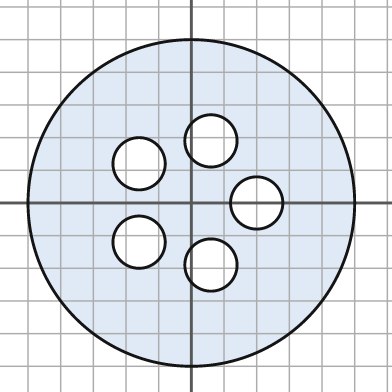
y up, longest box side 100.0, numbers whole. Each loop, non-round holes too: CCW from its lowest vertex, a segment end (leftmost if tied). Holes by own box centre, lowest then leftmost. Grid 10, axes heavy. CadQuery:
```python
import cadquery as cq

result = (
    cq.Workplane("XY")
    .moveTo(0.0, 0.0)
    .circle(50.0)
    .moveTo(6.0, -19.0)
    .circle(8.0)
    .moveTo(-16.0, -12.0)
    .circle(8.0)
    .moveTo(20.0, 0.0)
    .circle(8.0)
    .moveTo(-16.0, 12.0)
    .circle(8.0)
    .moveTo(6.0, 19.0)
    .circle(8.0)
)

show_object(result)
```